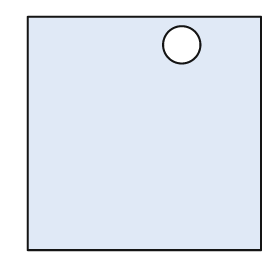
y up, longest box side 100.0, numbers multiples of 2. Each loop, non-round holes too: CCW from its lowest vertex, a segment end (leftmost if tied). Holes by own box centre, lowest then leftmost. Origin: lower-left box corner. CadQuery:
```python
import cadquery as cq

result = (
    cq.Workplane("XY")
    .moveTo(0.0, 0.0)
    .lineTo(100.0, 0.0)
    .lineTo(100.0, 100.0)
    .lineTo(0.0, 100.0)
    .close()
    .moveTo(66.0, 88.0)
    .circle(8.0)
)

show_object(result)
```